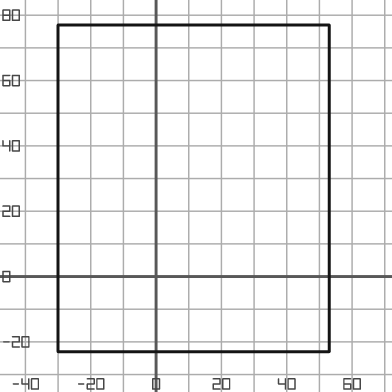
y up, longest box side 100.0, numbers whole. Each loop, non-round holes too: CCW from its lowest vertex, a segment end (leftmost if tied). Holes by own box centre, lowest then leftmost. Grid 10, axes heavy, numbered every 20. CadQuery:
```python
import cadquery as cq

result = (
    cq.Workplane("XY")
    .moveTo(-30.0, -23.0)
    .lineTo(53.0, -23.0)
    .lineTo(53.0, 77.0)
    .lineTo(-30.0, 77.0)
    .close()
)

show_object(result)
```